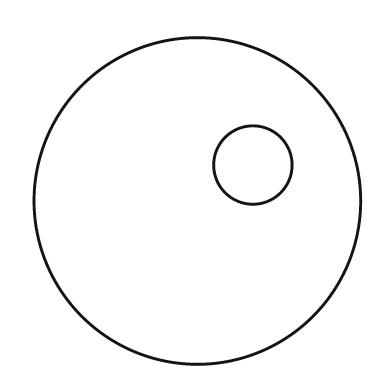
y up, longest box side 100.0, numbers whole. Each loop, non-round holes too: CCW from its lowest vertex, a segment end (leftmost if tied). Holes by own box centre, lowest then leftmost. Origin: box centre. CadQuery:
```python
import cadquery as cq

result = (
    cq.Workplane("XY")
    .moveTo(0.0, 0.0)
    .circle(50.0)
    .moveTo(17.0, 11.0)
    .circle(12.0)
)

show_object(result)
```